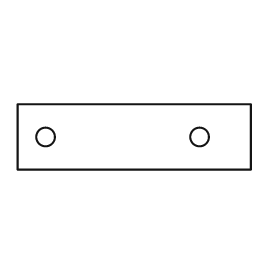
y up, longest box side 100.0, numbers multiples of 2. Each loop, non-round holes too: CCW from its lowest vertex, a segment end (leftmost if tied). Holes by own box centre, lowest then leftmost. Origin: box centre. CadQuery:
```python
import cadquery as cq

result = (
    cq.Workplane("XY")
    .moveTo(-50.0, -14.0)
    .lineTo(50.0, -14.0)
    .lineTo(50.0, 14.0)
    .lineTo(-50.0, 14.0)
    .close()
    .moveTo(-38.0, 0.0)
    .circle(4.0)
    .moveTo(28.0, 0.0)
    .circle(4.0)
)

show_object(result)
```